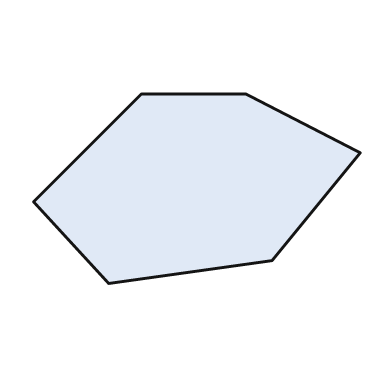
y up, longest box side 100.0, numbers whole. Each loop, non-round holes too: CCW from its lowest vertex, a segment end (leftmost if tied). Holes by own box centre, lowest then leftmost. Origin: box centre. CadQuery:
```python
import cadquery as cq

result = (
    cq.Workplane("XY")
    .moveTo(-27.0, -29.0)
    .lineTo(23.0, -22.0)
    .lineTo(50.0, 11.0)
    .lineTo(15.0, 29.0)
    .lineTo(-17.0, 29.0)
    .lineTo(-50.0, -4.0)
    .close()
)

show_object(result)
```